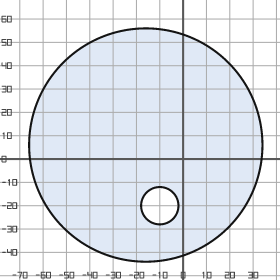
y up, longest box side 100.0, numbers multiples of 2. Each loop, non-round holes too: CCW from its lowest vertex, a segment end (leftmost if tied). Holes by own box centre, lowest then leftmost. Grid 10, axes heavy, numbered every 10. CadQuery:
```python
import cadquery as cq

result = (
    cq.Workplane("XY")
    .moveTo(-16.0, 6.0)
    .circle(50.0)
    .moveTo(-10.0, -20.0)
    .circle(8.0)
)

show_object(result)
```